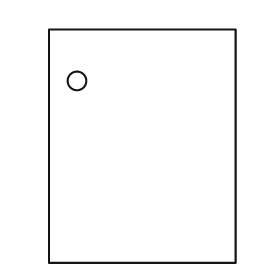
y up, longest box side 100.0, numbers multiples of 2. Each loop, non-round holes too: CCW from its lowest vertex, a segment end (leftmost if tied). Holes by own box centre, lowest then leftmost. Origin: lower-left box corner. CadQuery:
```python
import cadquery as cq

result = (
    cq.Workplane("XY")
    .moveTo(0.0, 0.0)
    .lineTo(80.0, 0.0)
    .lineTo(80.0, 100.0)
    .lineTo(0.0, 100.0)
    .close()
    .moveTo(12.0, 78.0)
    .circle(4.0)
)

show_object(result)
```